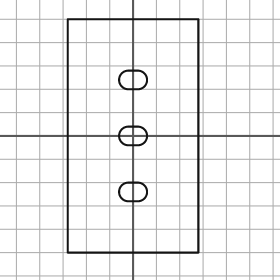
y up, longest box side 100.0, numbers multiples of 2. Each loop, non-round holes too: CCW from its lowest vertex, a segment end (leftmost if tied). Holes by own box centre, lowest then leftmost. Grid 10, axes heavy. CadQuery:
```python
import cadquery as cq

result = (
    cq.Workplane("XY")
    .moveTo(-28.0, -50.0)
    .lineTo(28.0, -50.0)
    .lineTo(28.0, 50.0)
    .lineTo(-28.0, 50.0)
    .close()
    .moveTo(-2.0, -28.0)
    .lineTo(2.0, -28.0)
    .threePointArc((6.0, -24.0), (2.0, -20.0))
    .lineTo(-2.0, -20.0)
    .threePointArc((-6.0, -24.0), (-2.0, -28.0))
    .close()
    .moveTo(-2.0, -4.0)
    .lineTo(2.0, -4.0)
    .threePointArc((6.0, 0.0), (2.0, 4.0))
    .lineTo(-2.0, 4.0)
    .threePointArc((-6.0, 0.0), (-2.0, -4.0))
    .close()
    .moveTo(-2.0, 20.0)
    .lineTo(2.0, 20.0)
    .threePointArc((6.0, 24.0), (2.0, 28.0))
    .lineTo(-2.0, 28.0)
    .threePointArc((-6.0, 24.0), (-2.0, 20.0))
    .close()
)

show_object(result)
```